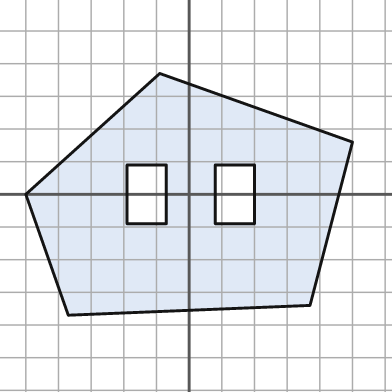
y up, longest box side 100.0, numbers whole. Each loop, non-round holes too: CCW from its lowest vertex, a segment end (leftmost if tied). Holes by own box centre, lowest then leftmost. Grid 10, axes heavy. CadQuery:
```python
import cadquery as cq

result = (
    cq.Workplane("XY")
    .moveTo(-37.0, -37.0)
    .lineTo(37.0, -34.0)
    .lineTo(50.0, 16.0)
    .lineTo(-9.0, 37.0)
    .lineTo(-50.0, 0.0)
    .close()
    .moveTo(-19.0, -9.0)
    .lineTo(-7.0, -9.0)
    .lineTo(-7.0, 9.0)
    .lineTo(-19.0, 9.0)
    .close()
    .moveTo(8.0, -9.0)
    .lineTo(20.0, -9.0)
    .lineTo(20.0, 9.0)
    .lineTo(8.0, 9.0)
    .close()
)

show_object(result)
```